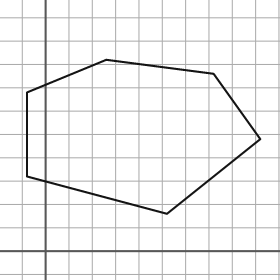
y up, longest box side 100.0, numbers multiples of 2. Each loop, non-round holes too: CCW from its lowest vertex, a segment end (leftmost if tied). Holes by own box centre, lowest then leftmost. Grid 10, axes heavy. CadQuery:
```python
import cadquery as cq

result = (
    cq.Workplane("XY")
    .moveTo(52.0, 16.0)
    .lineTo(92.0, 48.0)
    .lineTo(72.0, 76.0)
    .lineTo(26.0, 82.0)
    .lineTo(-8.0, 68.0)
    .lineTo(-8.0, 32.0)
    .close()
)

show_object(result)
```